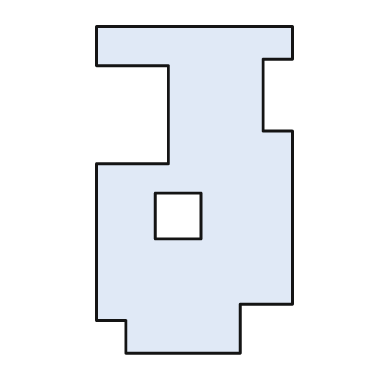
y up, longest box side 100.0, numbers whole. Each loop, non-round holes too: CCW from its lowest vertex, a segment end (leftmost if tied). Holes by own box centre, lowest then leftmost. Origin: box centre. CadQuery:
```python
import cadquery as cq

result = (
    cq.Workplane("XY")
    .moveTo(-21.0, -50.0)
    .lineTo(14.0, -50.0)
    .lineTo(14.0, -35.0)
    .lineTo(30.0, -35.0)
    .lineTo(30.0, 18.0)
    .lineTo(21.0, 18.0)
    .lineTo(21.0, 40.0)
    .lineTo(30.0, 40.0)
    .lineTo(30.0, 50.0)
    .lineTo(-30.0, 50.0)
    .lineTo(-30.0, 38.0)
    .lineTo(-8.0, 38.0)
    .lineTo(-8.0, 8.0)
    .lineTo(-30.0, 8.0)
    .lineTo(-30.0, -40.0)
    .lineTo(-21.0, -40.0)
    .close()
    .moveTo(-12.0, -15.0)
    .lineTo(2.0, -15.0)
    .lineTo(2.0, -1.0)
    .lineTo(-12.0, -1.0)
    .close()
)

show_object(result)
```